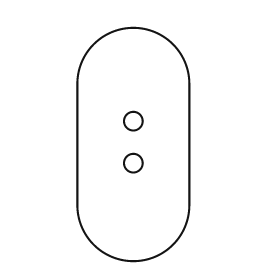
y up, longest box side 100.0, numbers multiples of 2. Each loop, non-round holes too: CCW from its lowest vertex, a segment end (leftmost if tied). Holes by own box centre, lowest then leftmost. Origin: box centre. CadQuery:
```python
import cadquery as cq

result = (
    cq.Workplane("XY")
    .moveTo(-24.0, -26.0)
    .threePointArc((0.0, -50.0), (24.0, -26.0))
    .lineTo(24.0, 26.0)
    .threePointArc((0.0, 50.0), (-24.0, 26.0))
    .close()
    .moveTo(0.0, -8.0)
    .circle(4.0)
    .moveTo(0.0, 10.0)
    .circle(4.0)
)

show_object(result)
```